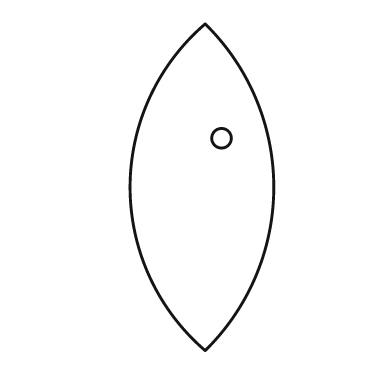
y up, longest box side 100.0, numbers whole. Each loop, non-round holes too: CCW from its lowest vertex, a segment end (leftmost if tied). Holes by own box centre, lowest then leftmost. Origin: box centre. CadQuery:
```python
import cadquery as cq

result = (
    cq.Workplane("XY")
    .moveTo(1.0, -50.0)
    .threePointArc((22.0, 0.0), (1.0, 50.0))
    .threePointArc((-22.0, 0.0), (1.0, -50.0))
    .close()
    .moveTo(6.0, 15.0)
    .circle(3.0)
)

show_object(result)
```